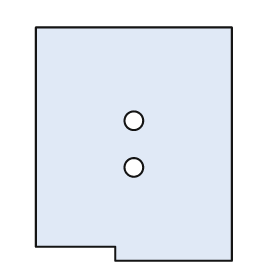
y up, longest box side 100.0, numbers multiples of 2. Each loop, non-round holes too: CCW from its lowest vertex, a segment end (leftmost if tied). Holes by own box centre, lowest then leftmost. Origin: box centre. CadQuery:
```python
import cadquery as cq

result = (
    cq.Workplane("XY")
    .moveTo(-8.0, -50.0)
    .lineTo(42.0, -50.0)
    .lineTo(42.0, 50.0)
    .lineTo(-42.0, 50.0)
    .lineTo(-42.0, -44.0)
    .lineTo(-8.0, -44.0)
    .close()
    .moveTo(0.0, -10.0)
    .circle(4.0)
    .moveTo(0.0, 10.0)
    .circle(4.0)
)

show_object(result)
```